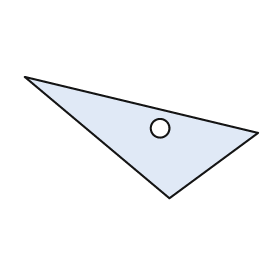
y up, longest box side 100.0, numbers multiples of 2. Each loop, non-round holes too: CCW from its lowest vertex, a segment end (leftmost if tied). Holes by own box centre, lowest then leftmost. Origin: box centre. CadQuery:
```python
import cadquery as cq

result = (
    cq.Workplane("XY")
    .moveTo(12.0, -26.0)
    .lineTo(50.0, 2.0)
    .lineTo(-50.0, 26.0)
    .close()
    .moveTo(8.0, 4.0)
    .circle(4.0)
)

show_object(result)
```